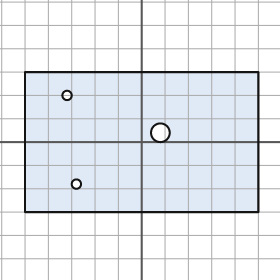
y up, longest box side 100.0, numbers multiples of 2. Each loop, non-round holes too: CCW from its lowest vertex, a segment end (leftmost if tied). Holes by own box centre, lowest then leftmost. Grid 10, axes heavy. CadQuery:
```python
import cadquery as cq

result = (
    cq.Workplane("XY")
    .moveTo(-50.0, -30.0)
    .lineTo(50.0, -30.0)
    .lineTo(50.0, 30.0)
    .lineTo(-50.0, 30.0)
    .close()
    .moveTo(-28.0, -18.0)
    .circle(2.0)
    .moveTo(8.0, 4.0)
    .circle(4.0)
    .moveTo(-32.0, 20.0)
    .circle(2.0)
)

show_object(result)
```